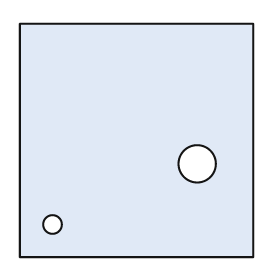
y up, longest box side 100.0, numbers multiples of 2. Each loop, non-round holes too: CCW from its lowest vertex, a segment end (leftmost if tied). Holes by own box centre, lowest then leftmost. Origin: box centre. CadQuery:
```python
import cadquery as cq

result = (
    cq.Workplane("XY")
    .moveTo(-50.0, -50.0)
    .lineTo(50.0, -50.0)
    .lineTo(50.0, 50.0)
    .lineTo(-50.0, 50.0)
    .close()
    .moveTo(-36.0, -36.0)
    .circle(4.0)
    .moveTo(26.0, -10.0)
    .circle(8.0)
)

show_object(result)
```